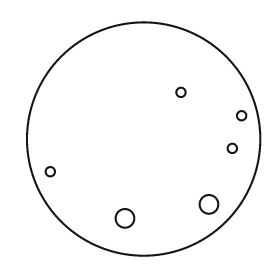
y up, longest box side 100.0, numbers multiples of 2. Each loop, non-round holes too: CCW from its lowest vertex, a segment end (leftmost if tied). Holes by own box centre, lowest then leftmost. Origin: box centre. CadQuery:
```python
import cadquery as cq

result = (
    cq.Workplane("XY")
    .moveTo(0.0, 0.0)
    .circle(50.0)
    .moveTo(-8.0, -34.0)
    .circle(4.0)
    .moveTo(28.0, -28.0)
    .circle(4.0)
    .moveTo(-40.0, -14.0)
    .circle(2.0)
    .moveTo(38.0, -4.0)
    .circle(2.0)
    .moveTo(42.0, 10.0)
    .circle(2.0)
    .moveTo(16.0, 20.0)
    .circle(2.0)
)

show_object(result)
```